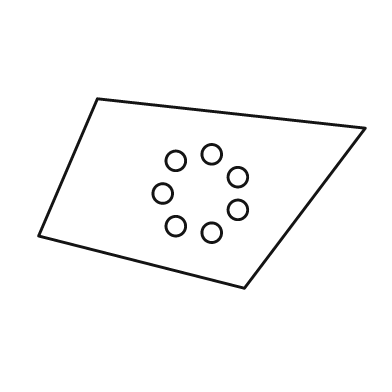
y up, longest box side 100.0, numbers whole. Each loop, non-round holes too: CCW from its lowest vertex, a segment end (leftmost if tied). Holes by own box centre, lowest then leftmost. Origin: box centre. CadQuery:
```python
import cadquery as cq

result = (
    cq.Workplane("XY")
    .moveTo(13.0, -29.0)
    .lineTo(50.0, 20.0)
    .lineTo(-32.0, 29.0)
    .lineTo(-50.0, -13.0)
    .close()
    .moveTo(3.0, -12.0)
    .circle(3.0)
    .moveTo(-8.0, -10.0)
    .circle(3.0)
    .moveTo(11.0, -5.0)
    .circle(3.0)
    .moveTo(-12.0, 0.0)
    .circle(3.0)
    .moveTo(11.0, 5.0)
    .circle(3.0)
    .moveTo(-8.0, 10.0)
    .circle(3.0)
    .moveTo(3.0, 12.0)
    .circle(3.0)
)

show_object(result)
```